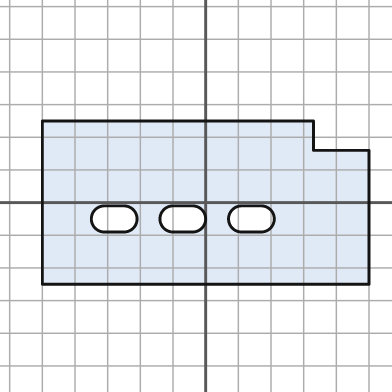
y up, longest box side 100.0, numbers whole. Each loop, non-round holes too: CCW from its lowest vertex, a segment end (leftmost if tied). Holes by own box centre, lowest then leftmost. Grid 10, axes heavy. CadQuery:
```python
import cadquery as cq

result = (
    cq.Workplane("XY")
    .moveTo(-50.0, -25.0)
    .lineTo(50.0, -25.0)
    .lineTo(50.0, 16.0)
    .lineTo(33.0, 16.0)
    .lineTo(33.0, 25.0)
    .lineTo(-50.0, 25.0)
    .close()
    .moveTo(-31.0, -9.0)
    .lineTo(-25.0, -9.0)
    .threePointArc((-21.0, -5.0), (-25.0, -1.0))
    .lineTo(-31.0, -1.0)
    .threePointArc((-35.0, -5.0), (-31.0, -9.0))
    .close()
    .moveTo(-10.0, -9.0)
    .lineTo(-4.0, -9.0)
    .threePointArc((0.0, -5.0), (-4.0, -1.0))
    .lineTo(-10.0, -1.0)
    .threePointArc((-14.0, -5.0), (-10.0, -9.0))
    .close()
    .moveTo(11.0, -9.0)
    .lineTo(17.0, -9.0)
    .threePointArc((21.0, -5.0), (17.0, -1.0))
    .lineTo(11.0, -1.0)
    .threePointArc((7.0, -5.0), (11.0, -9.0))
    .close()
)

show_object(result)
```